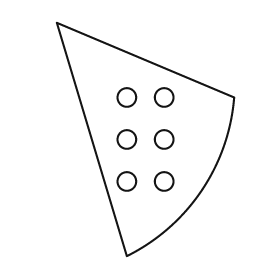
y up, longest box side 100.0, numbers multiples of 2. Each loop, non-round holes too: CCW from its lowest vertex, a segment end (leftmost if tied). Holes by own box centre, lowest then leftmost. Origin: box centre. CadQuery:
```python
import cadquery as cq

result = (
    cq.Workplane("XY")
    .moveTo(-8.0, -50.0)
    .threePointArc((24.0, -22.0), (38.0, 18.0))
    .lineTo(-38.0, 50.0)
    .close()
    .moveTo(-8.0, -18.0)
    .circle(4.0)
    .moveTo(8.0, -18.0)
    .circle(4.0)
    .moveTo(-8.0, 0.0)
    .circle(4.0)
    .moveTo(8.0, 0.0)
    .circle(4.0)
    .moveTo(-8.0, 18.0)
    .circle(4.0)
    .moveTo(8.0, 18.0)
    .circle(4.0)
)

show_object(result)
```